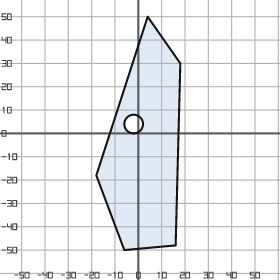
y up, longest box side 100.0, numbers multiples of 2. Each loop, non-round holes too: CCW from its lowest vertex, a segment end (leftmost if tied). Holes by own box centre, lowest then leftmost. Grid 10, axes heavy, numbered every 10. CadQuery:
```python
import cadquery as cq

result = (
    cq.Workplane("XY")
    .moveTo(-6.0, -50.0)
    .lineTo(16.0, -48.0)
    .lineTo(18.0, 30.0)
    .lineTo(4.0, 50.0)
    .lineTo(-18.0, -18.0)
    .close()
    .moveTo(-2.0, 4.0)
    .circle(4.0)
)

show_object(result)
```